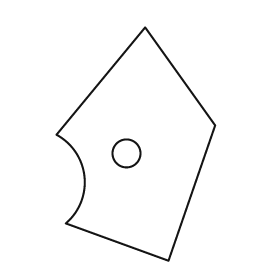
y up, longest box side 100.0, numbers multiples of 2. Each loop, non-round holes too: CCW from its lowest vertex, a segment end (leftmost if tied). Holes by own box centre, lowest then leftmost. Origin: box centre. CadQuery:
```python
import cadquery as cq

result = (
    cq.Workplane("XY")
    .moveTo(14.0, -50.0)
    .lineTo(34.0, 8.0)
    .lineTo(4.0, 50.0)
    .lineTo(-34.0, 4.0)
    .threePointArc((-22.0, -14.0), (-30.0, -34.0))
    .close()
    .moveTo(-4.0, -4.0)
    .circle(6.0)
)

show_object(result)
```